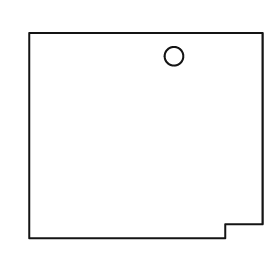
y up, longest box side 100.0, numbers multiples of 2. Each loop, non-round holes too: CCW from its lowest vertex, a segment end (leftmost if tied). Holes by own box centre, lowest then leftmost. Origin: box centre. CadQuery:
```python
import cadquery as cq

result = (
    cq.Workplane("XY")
    .moveTo(-50.0, -44.0)
    .lineTo(34.0, -44.0)
    .lineTo(34.0, -38.0)
    .lineTo(50.0, -38.0)
    .lineTo(50.0, 44.0)
    .lineTo(-50.0, 44.0)
    .close()
    .moveTo(12.0, 34.0)
    .circle(4.0)
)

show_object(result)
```